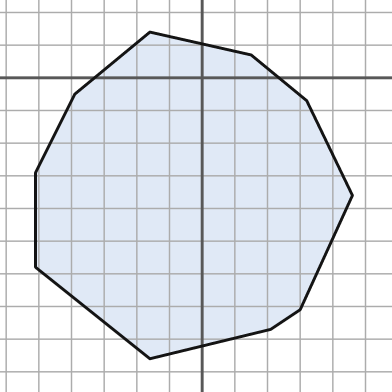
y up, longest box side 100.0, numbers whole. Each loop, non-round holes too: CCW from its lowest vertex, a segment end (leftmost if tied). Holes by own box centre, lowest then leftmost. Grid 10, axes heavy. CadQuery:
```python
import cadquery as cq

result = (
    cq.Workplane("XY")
    .moveTo(-16.0, -86.0)
    .lineTo(21.0, -77.0)
    .lineTo(30.0, -71.0)
    .lineTo(46.0, -36.0)
    .lineTo(32.0, -7.0)
    .lineTo(15.0, 7.0)
    .lineTo(-16.0, 14.0)
    .lineTo(-39.0, -5.0)
    .lineTo(-51.0, -29.0)
    .lineTo(-51.0, -58.0)
    .close()
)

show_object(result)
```